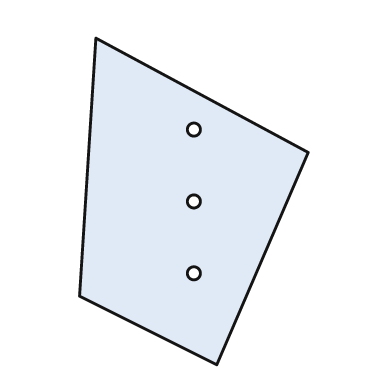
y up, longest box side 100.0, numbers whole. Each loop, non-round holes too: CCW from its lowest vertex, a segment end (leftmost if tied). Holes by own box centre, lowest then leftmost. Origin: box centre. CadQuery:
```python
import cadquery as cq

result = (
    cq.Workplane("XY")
    .moveTo(7.0, -50.0)
    .lineTo(35.0, 15.0)
    .lineTo(-30.0, 50.0)
    .lineTo(-35.0, -29.0)
    .close()
    .moveTo(0.0, -22.0)
    .circle(2.0)
    .moveTo(0.0, 0.0)
    .circle(2.0)
    .moveTo(0.0, 22.0)
    .circle(2.0)
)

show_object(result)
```